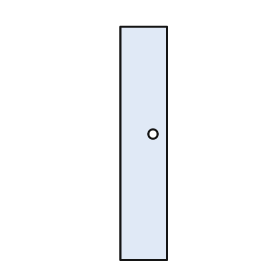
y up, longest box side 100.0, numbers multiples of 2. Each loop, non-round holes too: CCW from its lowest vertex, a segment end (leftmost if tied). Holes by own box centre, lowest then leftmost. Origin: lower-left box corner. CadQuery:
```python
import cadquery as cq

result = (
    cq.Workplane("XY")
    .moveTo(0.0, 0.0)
    .lineTo(20.0, 0.0)
    .lineTo(20.0, 100.0)
    .lineTo(0.0, 100.0)
    .close()
    .moveTo(14.0, 54.0)
    .circle(2.0)
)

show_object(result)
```